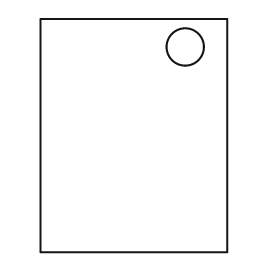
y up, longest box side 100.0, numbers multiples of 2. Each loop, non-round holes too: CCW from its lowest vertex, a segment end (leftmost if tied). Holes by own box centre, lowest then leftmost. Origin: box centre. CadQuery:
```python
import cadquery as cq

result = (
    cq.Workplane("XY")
    .moveTo(-40.0, -50.0)
    .lineTo(40.0, -50.0)
    .lineTo(40.0, 50.0)
    .lineTo(-40.0, 50.0)
    .close()
    .moveTo(22.0, 38.0)
    .circle(8.0)
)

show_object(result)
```